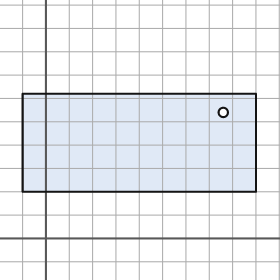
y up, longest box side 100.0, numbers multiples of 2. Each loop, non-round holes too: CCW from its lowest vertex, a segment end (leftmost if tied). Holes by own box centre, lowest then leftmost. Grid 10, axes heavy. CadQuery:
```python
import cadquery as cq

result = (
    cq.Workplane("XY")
    .moveTo(-10.0, 20.0)
    .lineTo(90.0, 20.0)
    .lineTo(90.0, 62.0)
    .lineTo(-10.0, 62.0)
    .close()
    .moveTo(76.0, 54.0)
    .circle(2.0)
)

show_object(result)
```